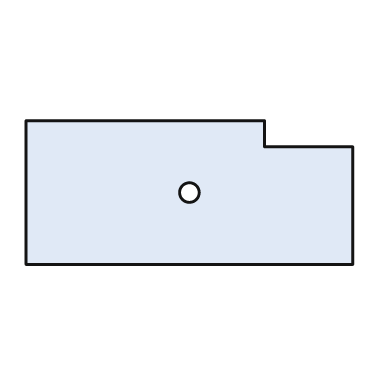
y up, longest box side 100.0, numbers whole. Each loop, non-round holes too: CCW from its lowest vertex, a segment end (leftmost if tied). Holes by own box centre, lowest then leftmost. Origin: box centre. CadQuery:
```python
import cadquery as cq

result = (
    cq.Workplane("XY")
    .moveTo(-50.0, -22.0)
    .lineTo(50.0, -22.0)
    .lineTo(50.0, 14.0)
    .lineTo(23.0, 14.0)
    .lineTo(23.0, 22.0)
    .lineTo(-50.0, 22.0)
    .close()
    .moveTo(0.0, 0.0)
    .circle(3.0)
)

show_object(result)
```